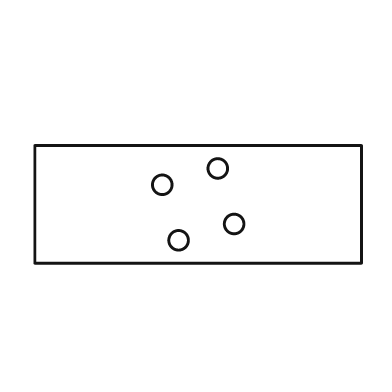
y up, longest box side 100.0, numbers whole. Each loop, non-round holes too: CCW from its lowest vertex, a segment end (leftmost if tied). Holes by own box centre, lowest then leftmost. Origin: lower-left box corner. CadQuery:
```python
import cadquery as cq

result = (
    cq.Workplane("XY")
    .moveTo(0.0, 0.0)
    .lineTo(100.0, 0.0)
    .lineTo(100.0, 36.0)
    .lineTo(0.0, 36.0)
    .close()
    .moveTo(44.0, 7.0)
    .circle(3.0)
    .moveTo(61.0, 12.0)
    .circle(3.0)
    .moveTo(39.0, 24.0)
    .circle(3.0)
    .moveTo(56.0, 29.0)
    .circle(3.0)
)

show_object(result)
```